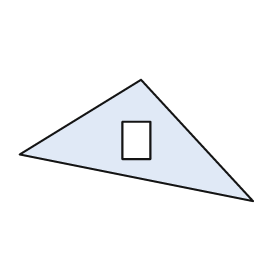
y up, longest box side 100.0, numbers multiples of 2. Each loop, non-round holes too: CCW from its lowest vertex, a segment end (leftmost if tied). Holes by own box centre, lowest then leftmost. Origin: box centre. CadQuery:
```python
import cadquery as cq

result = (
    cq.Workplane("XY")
    .moveTo(50.0, -26.0)
    .lineTo(2.0, 26.0)
    .lineTo(-50.0, -6.0)
    .close()
    .moveTo(-6.0, -8.0)
    .lineTo(6.0, -8.0)
    .lineTo(6.0, 8.0)
    .lineTo(-6.0, 8.0)
    .close()
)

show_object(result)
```